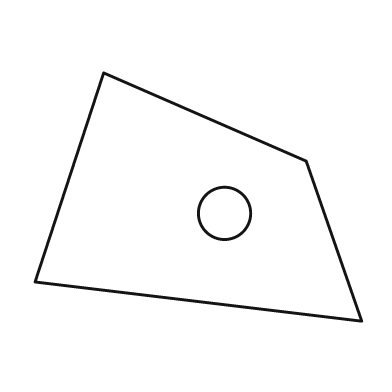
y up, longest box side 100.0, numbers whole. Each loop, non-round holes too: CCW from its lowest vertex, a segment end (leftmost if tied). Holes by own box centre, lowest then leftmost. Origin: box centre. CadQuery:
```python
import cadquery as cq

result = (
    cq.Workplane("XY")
    .moveTo(50.0, -38.0)
    .lineTo(33.0, 11.0)
    .lineTo(-29.0, 38.0)
    .lineTo(-50.0, -26.0)
    .close()
    .moveTo(8.0, -5.0)
    .circle(8.0)
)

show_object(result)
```